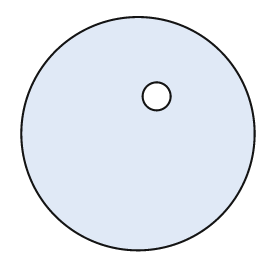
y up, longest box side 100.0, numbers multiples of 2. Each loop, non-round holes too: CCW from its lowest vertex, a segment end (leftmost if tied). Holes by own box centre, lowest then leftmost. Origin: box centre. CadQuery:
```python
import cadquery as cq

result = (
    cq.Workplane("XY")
    .moveTo(0.0, 0.0)
    .circle(50.0)
    .moveTo(8.0, 16.0)
    .circle(6.0)
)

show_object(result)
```